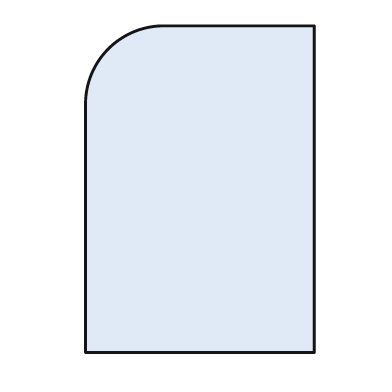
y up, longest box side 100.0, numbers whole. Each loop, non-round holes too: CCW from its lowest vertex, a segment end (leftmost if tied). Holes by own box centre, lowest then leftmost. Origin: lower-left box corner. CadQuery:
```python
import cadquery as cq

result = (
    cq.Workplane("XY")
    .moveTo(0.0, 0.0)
    .lineTo(70.0, 0.0)
    .lineTo(70.0, 100.0)
    .lineTo(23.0, 100.0)
    .threePointArc((7.0, 93.0), (0.0, 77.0))
    .close()
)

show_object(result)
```